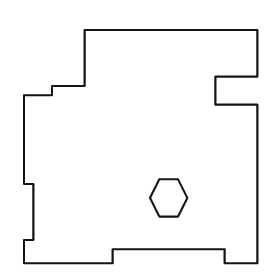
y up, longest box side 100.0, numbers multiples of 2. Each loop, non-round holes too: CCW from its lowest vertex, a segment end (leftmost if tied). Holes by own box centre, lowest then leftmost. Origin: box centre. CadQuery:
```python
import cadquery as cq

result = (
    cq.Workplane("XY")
    .moveTo(-50.0, -50.0)
    .lineTo(-12.0, -50.0)
    .lineTo(-12.0, -44.0)
    .lineTo(36.0, -44.0)
    .lineTo(36.0, -50.0)
    .lineTo(50.0, -50.0)
    .lineTo(50.0, 18.0)
    .lineTo(32.0, 18.0)
    .lineTo(32.0, 30.0)
    .lineTo(50.0, 30.0)
    .lineTo(50.0, 50.0)
    .lineTo(-24.0, 50.0)
    .lineTo(-24.0, 26.0)
    .lineTo(-38.0, 26.0)
    .lineTo(-38.0, 22.0)
    .lineTo(-50.0, 22.0)
    .lineTo(-50.0, -16.0)
    .lineTo(-46.0, -16.0)
    .lineTo(-46.0, -40.0)
    .lineTo(-50.0, -40.0)
    .close()
    .moveTo(8.0, -30.0)
    .lineTo(16.0, -30.0)
    .lineTo(20.0, -22.0)
    .lineTo(16.0, -14.0)
    .lineTo(8.0, -14.0)
    .lineTo(4.0, -22.0)
    .close()
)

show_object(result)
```